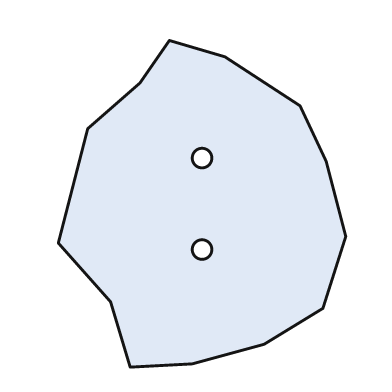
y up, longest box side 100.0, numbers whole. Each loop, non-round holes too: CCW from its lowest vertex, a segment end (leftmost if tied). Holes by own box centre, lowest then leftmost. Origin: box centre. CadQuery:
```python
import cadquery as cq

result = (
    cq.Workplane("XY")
    .moveTo(-22.0, -50.0)
    .lineTo(-3.0, -49.0)
    .lineTo(19.0, -43.0)
    .lineTo(37.0, -32.0)
    .lineTo(44.0, -10.0)
    .lineTo(38.0, 13.0)
    .lineTo(30.0, 30.0)
    .lineTo(7.0, 45.0)
    .lineTo(-10.0, 50.0)
    .lineTo(-19.0, 37.0)
    .lineTo(-35.0, 23.0)
    .lineTo(-44.0, -12.0)
    .lineTo(-28.0, -30.0)
    .close()
    .moveTo(0.0, -14.0)
    .circle(3.0)
    .moveTo(0.0, 14.0)
    .circle(3.0)
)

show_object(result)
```